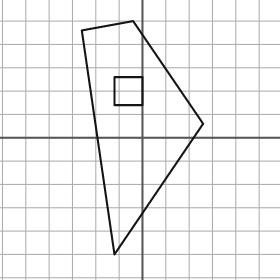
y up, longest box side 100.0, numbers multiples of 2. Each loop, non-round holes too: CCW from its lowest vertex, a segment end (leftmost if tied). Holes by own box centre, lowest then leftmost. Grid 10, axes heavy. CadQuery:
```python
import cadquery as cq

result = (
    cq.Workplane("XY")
    .moveTo(-12.0, -50.0)
    .lineTo(26.0, 6.0)
    .lineTo(-4.0, 50.0)
    .lineTo(-26.0, 46.0)
    .close()
    .moveTo(-12.0, 14.0)
    .lineTo(0.0, 14.0)
    .lineTo(0.0, 26.0)
    .lineTo(-12.0, 26.0)
    .close()
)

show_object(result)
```